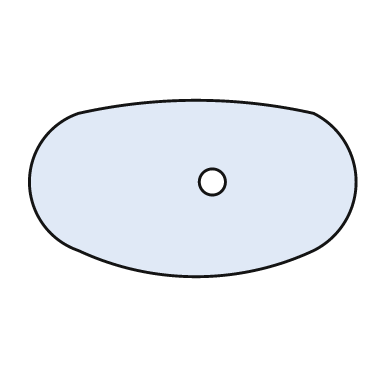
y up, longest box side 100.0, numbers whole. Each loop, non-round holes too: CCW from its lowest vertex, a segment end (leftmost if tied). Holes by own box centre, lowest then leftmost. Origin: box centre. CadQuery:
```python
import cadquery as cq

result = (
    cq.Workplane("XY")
    .moveTo(-35.0, -19.0)
    .threePointArc((1.0, -27.0), (37.0, -19.0))
    .threePointArc((50.0, 2.0), (37.0, 23.0))
    .threePointArc((1.0, 27.0), (-35.0, 23.0))
    .threePointArc((-50.0, 2.0), (-35.0, -19.0))
    .close()
    .moveTo(6.0, 2.0)
    .circle(4.0)
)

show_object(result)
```